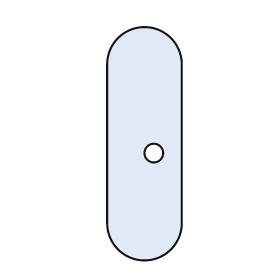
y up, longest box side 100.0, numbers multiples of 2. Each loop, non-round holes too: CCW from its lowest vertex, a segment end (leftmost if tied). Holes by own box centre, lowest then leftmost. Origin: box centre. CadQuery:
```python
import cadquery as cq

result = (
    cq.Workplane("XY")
    .moveTo(-16.0, -34.0)
    .threePointArc((0.0, -50.0), (16.0, -34.0))
    .lineTo(16.0, 34.0)
    .threePointArc((0.0, 50.0), (-16.0, 34.0))
    .close()
    .moveTo(4.0, -4.0)
    .circle(4.0)
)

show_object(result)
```